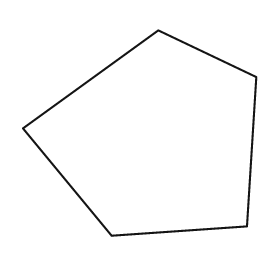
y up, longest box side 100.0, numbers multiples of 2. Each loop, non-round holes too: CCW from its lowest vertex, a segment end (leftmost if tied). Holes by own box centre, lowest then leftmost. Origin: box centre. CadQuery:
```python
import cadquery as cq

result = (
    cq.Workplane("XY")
    .moveTo(-12.0, -44.0)
    .lineTo(46.0, -40.0)
    .lineTo(50.0, 24.0)
    .lineTo(8.0, 44.0)
    .lineTo(-50.0, 2.0)
    .close()
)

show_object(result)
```